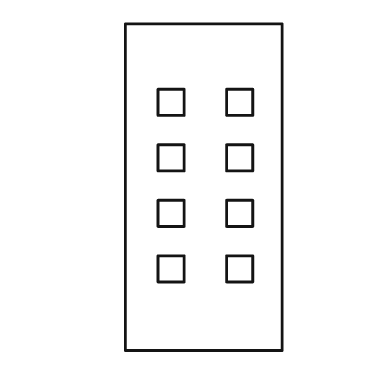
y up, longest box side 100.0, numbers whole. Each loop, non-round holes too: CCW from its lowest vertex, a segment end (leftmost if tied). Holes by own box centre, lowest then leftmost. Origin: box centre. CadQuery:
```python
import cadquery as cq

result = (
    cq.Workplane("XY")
    .moveTo(-24.0, -50.0)
    .lineTo(24.0, -50.0)
    .lineTo(24.0, 50.0)
    .lineTo(-24.0, 50.0)
    .close()
    .moveTo(-14.0, -29.0)
    .lineTo(-6.0, -29.0)
    .lineTo(-6.0, -21.0)
    .lineTo(-14.0, -21.0)
    .close()
    .moveTo(7.0, -29.0)
    .lineTo(15.0, -29.0)
    .lineTo(15.0, -21.0)
    .lineTo(7.0, -21.0)
    .close()
    .moveTo(-14.0, -12.0)
    .lineTo(-6.0, -12.0)
    .lineTo(-6.0, -4.0)
    .lineTo(-14.0, -4.0)
    .close()
    .moveTo(7.0, -12.0)
    .lineTo(15.0, -12.0)
    .lineTo(15.0, -4.0)
    .lineTo(7.0, -4.0)
    .close()
    .moveTo(-14.0, 5.0)
    .lineTo(-6.0, 5.0)
    .lineTo(-6.0, 13.0)
    .lineTo(-14.0, 13.0)
    .close()
    .moveTo(7.0, 5.0)
    .lineTo(15.0, 5.0)
    .lineTo(15.0, 13.0)
    .lineTo(7.0, 13.0)
    .close()
    .moveTo(-14.0, 22.0)
    .lineTo(-6.0, 22.0)
    .lineTo(-6.0, 30.0)
    .lineTo(-14.0, 30.0)
    .close()
    .moveTo(7.0, 22.0)
    .lineTo(15.0, 22.0)
    .lineTo(15.0, 30.0)
    .lineTo(7.0, 30.0)
    .close()
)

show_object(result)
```